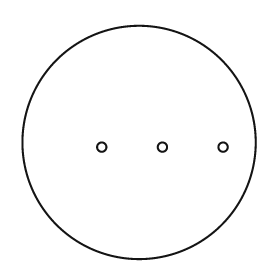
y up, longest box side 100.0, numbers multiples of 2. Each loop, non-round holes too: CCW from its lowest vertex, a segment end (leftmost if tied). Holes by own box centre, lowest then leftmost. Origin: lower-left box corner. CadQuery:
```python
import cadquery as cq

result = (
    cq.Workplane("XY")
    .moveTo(50.0, 50.0)
    .circle(50.0)
    .moveTo(34.0, 48.0)
    .circle(2.0)
    .moveTo(60.0, 48.0)
    .circle(2.0)
    .moveTo(86.0, 48.0)
    .circle(2.0)
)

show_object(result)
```